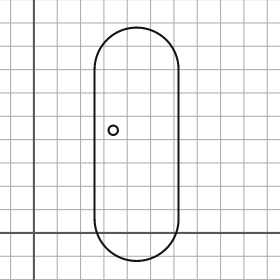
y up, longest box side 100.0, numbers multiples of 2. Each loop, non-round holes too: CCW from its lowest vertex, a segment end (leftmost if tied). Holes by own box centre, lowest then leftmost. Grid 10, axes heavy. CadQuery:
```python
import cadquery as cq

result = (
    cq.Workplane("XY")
    .moveTo(26.0, 6.0)
    .threePointArc((44.0, -12.0), (62.0, 6.0))
    .lineTo(62.0, 70.0)
    .threePointArc((44.0, 88.0), (26.0, 70.0))
    .close()
    .moveTo(34.0, 44.0)
    .circle(2.0)
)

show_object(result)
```